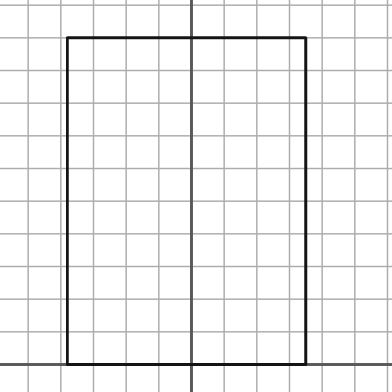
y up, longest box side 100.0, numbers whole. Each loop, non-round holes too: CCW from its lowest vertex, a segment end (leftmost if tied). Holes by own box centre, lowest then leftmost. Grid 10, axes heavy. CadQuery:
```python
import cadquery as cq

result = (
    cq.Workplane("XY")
    .moveTo(-38.0, 0.0)
    .lineTo(35.0, 0.0)
    .lineTo(35.0, 100.0)
    .lineTo(-38.0, 100.0)
    .close()
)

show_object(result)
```